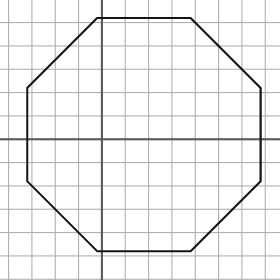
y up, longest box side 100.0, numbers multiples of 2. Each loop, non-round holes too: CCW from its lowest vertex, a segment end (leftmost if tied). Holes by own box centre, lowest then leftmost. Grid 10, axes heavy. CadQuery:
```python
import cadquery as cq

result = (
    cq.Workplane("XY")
    .moveTo(-2.0, -48.0)
    .lineTo(38.0, -48.0)
    .lineTo(68.0, -18.0)
    .lineTo(68.0, 22.0)
    .lineTo(38.0, 52.0)
    .lineTo(-2.0, 52.0)
    .lineTo(-32.0, 22.0)
    .lineTo(-32.0, -18.0)
    .close()
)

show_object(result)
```